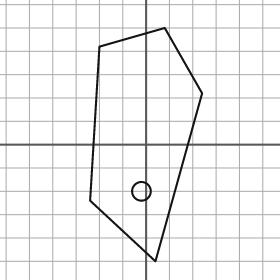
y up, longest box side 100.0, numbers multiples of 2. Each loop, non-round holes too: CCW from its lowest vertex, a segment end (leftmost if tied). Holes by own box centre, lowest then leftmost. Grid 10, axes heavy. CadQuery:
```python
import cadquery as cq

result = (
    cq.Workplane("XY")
    .moveTo(4.0, -50.0)
    .lineTo(24.0, 22.0)
    .lineTo(8.0, 50.0)
    .lineTo(-20.0, 42.0)
    .lineTo(-24.0, -24.0)
    .close()
    .moveTo(-2.0, -20.0)
    .circle(4.0)
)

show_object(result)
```